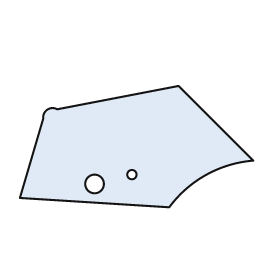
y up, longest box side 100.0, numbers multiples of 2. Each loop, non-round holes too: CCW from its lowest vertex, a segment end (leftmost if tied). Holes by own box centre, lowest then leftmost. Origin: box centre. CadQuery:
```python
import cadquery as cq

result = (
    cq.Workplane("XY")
    .moveTo(14.0, -26.0)
    .threePointArc((30.0, -12.0), (50.0, -6.0))
    .lineTo(18.0, 26.0)
    .lineTo(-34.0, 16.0)
    .threePointArc((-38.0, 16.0), (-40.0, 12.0))
    .lineTo(-50.0, -22.0)
    .close()
    .moveTo(-18.0, -16.0)
    .circle(4.0)
    .moveTo(-2.0, -12.0)
    .circle(2.0)
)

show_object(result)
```